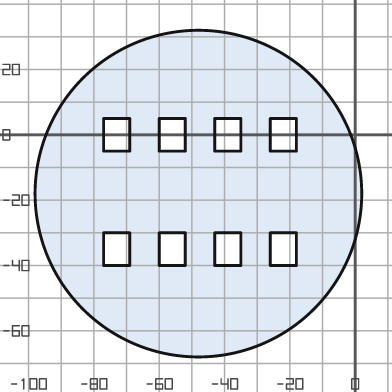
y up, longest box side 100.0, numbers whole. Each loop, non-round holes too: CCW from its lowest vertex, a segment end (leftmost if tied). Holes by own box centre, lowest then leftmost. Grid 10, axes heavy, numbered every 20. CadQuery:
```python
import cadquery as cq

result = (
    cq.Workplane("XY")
    .moveTo(-48.0, -18.0)
    .circle(50.0)
    .moveTo(-77.0, -40.0)
    .lineTo(-69.0, -40.0)
    .lineTo(-69.0, -30.0)
    .lineTo(-77.0, -30.0)
    .close()
    .moveTo(-60.0, -40.0)
    .lineTo(-52.0, -40.0)
    .lineTo(-52.0, -30.0)
    .lineTo(-60.0, -30.0)
    .close()
    .moveTo(-43.0, -40.0)
    .lineTo(-35.0, -40.0)
    .lineTo(-35.0, -30.0)
    .lineTo(-43.0, -30.0)
    .close()
    .moveTo(-26.0, -40.0)
    .lineTo(-18.0, -40.0)
    .lineTo(-18.0, -30.0)
    .lineTo(-26.0, -30.0)
    .close()
    .moveTo(-77.0, -5.0)
    .lineTo(-69.0, -5.0)
    .lineTo(-69.0, 5.0)
    .lineTo(-77.0, 5.0)
    .close()
    .moveTo(-60.0, -5.0)
    .lineTo(-52.0, -5.0)
    .lineTo(-52.0, 5.0)
    .lineTo(-60.0, 5.0)
    .close()
    .moveTo(-43.0, -5.0)
    .lineTo(-35.0, -5.0)
    .lineTo(-35.0, 5.0)
    .lineTo(-43.0, 5.0)
    .close()
    .moveTo(-26.0, -5.0)
    .lineTo(-18.0, -5.0)
    .lineTo(-18.0, 5.0)
    .lineTo(-26.0, 5.0)
    .close()
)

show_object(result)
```